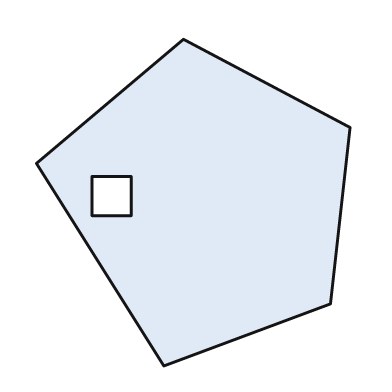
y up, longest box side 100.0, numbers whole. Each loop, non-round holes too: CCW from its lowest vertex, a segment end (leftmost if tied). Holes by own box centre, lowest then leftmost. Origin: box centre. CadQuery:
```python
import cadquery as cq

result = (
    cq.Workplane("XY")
    .moveTo(-9.0, -50.0)
    .lineTo(42.0, -31.0)
    .lineTo(48.0, 23.0)
    .lineTo(-3.0, 50.0)
    .lineTo(-48.0, 12.0)
    .close()
    .moveTo(-31.0, -4.0)
    .lineTo(-19.0, -4.0)
    .lineTo(-19.0, 8.0)
    .lineTo(-31.0, 8.0)
    .close()
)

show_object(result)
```